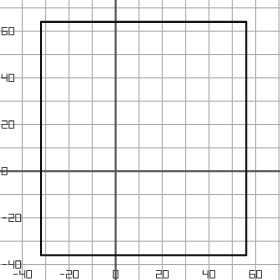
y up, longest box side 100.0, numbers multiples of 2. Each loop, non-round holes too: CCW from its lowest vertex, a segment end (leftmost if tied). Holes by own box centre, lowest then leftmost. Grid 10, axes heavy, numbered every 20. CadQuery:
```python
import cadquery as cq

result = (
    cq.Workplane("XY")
    .moveTo(-32.0, -36.0)
    .lineTo(56.0, -36.0)
    .lineTo(56.0, 64.0)
    .lineTo(-32.0, 64.0)
    .close()
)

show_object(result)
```